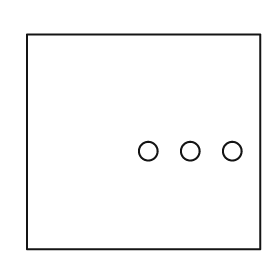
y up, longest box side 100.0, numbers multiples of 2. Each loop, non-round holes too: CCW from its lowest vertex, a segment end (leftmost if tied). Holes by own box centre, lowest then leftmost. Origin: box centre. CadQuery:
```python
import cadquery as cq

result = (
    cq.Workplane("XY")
    .moveTo(-50.0, -46.0)
    .lineTo(50.0, -46.0)
    .lineTo(50.0, 46.0)
    .lineTo(-50.0, 46.0)
    .close()
    .moveTo(2.0, -4.0)
    .circle(4.0)
    .moveTo(20.0, -4.0)
    .circle(4.0)
    .moveTo(38.0, -4.0)
    .circle(4.0)
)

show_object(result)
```